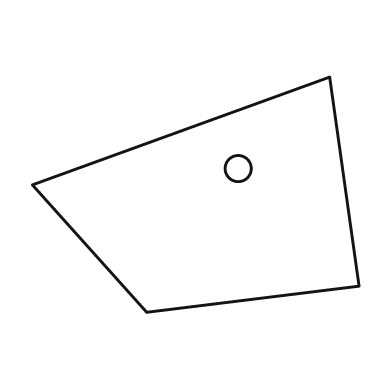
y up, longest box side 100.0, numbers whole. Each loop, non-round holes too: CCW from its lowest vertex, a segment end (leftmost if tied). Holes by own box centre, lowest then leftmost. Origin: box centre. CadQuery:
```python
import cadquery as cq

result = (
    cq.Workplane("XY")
    .moveTo(-15.0, -36.0)
    .lineTo(50.0, -28.0)
    .lineTo(41.0, 36.0)
    .lineTo(-50.0, 3.0)
    .close()
    .moveTo(13.0, 8.0)
    .circle(4.0)
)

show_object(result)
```